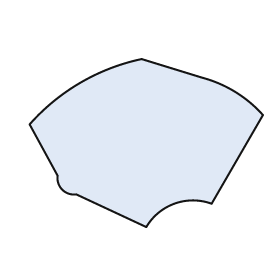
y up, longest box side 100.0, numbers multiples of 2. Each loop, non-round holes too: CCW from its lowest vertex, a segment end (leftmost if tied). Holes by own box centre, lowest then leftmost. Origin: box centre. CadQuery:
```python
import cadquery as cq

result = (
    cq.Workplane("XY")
    .moveTo(0.0, -36.0)
    .threePointArc((12.0, -26.0), (28.0, -26.0))
    .lineTo(50.0, 12.0)
    .threePointArc((38.0, 22.0), (24.0, 28.0))
    .lineTo(-2.0, 36.0)
    .threePointArc((-28.0, 26.0), (-50.0, 8.0))
    .lineTo(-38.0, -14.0)
    .threePointArc((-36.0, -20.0), (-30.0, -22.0))
    .close()
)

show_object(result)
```